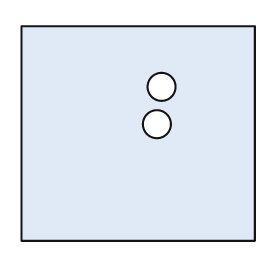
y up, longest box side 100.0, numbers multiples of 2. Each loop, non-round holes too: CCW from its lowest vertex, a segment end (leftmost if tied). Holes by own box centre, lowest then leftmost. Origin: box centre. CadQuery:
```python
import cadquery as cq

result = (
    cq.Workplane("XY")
    .moveTo(-50.0, -46.0)
    .lineTo(50.0, -46.0)
    .lineTo(50.0, 46.0)
    .lineTo(-50.0, 46.0)
    .close()
    .moveTo(8.0, 4.0)
    .circle(6.0)
    .moveTo(10.0, 20.0)
    .circle(6.0)
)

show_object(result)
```